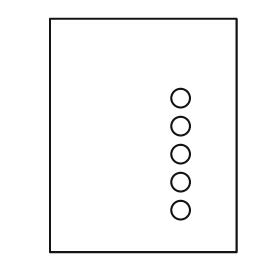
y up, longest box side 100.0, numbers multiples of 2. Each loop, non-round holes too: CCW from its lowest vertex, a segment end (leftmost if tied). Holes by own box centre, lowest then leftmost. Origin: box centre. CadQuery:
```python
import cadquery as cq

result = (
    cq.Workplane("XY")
    .moveTo(-40.0, -50.0)
    .lineTo(40.0, -50.0)
    .lineTo(40.0, 50.0)
    .lineTo(-40.0, 50.0)
    .close()
    .moveTo(16.0, -32.0)
    .circle(4.0)
    .moveTo(16.0, -20.0)
    .circle(4.0)
    .moveTo(16.0, -8.0)
    .circle(4.0)
    .moveTo(16.0, 4.0)
    .circle(4.0)
    .moveTo(16.0, 16.0)
    .circle(4.0)
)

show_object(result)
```